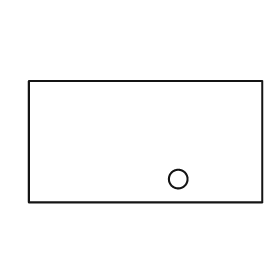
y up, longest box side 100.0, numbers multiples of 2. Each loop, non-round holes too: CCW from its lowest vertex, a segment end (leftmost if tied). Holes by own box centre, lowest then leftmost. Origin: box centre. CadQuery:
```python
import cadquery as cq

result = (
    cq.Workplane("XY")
    .moveTo(-50.0, -26.0)
    .lineTo(50.0, -26.0)
    .lineTo(50.0, 26.0)
    .lineTo(-50.0, 26.0)
    .close()
    .moveTo(14.0, -16.0)
    .circle(4.0)
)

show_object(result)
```